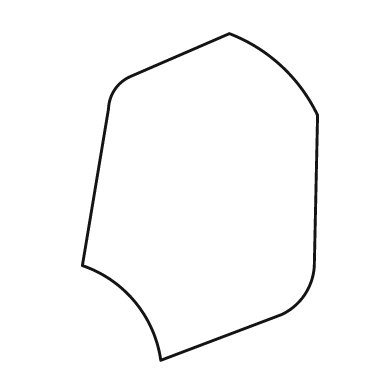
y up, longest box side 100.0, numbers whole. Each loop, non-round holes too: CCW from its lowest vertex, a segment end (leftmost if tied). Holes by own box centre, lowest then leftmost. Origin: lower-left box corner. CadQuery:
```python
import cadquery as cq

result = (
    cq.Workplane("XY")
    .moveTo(24.0, 0.0)
    .lineTo(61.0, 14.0)
    .threePointArc((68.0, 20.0), (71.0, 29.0))
    .lineTo(72.0, 75.0)
    .threePointArc((61.0, 90.0), (45.0, 100.0))
    .lineTo(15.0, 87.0)
    .threePointArc((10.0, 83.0), (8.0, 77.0))
    .lineTo(0.0, 29.0)
    .threePointArc((16.0, 18.0), (24.0, 0.0))
    .close()
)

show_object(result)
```